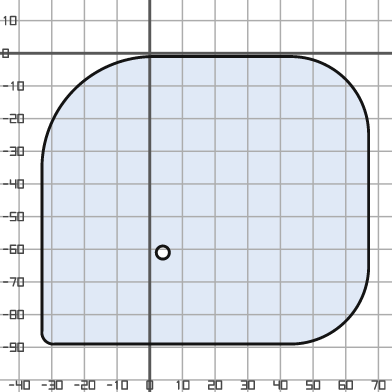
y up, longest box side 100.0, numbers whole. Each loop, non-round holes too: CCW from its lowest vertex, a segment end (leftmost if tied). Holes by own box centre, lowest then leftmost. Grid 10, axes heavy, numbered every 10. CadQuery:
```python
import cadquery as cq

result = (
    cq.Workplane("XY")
    .moveTo(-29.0, -89.0)
    .lineTo(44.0, -89.0)
    .threePointArc((60.0, -82.0), (67.0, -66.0))
    .lineTo(67.0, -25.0)
    .threePointArc((60.0, -8.0), (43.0, -1.0))
    .lineTo(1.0, -1.0)
    .threePointArc((-23.0, -11.0), (-33.0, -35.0))
    .lineTo(-33.0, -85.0)
    .threePointArc((-32.0, -88.0), (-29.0, -89.0))
    .close()
    .moveTo(4.0, -61.0)
    .circle(2.0)
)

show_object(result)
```